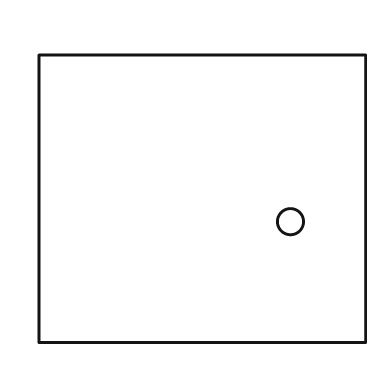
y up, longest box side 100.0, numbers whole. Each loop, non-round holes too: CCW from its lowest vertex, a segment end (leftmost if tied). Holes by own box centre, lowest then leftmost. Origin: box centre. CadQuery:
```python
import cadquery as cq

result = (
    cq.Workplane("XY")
    .moveTo(-50.0, -44.0)
    .lineTo(50.0, -44.0)
    .lineTo(50.0, 44.0)
    .lineTo(-50.0, 44.0)
    .close()
    .moveTo(27.0, -7.0)
    .circle(4.0)
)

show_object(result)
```